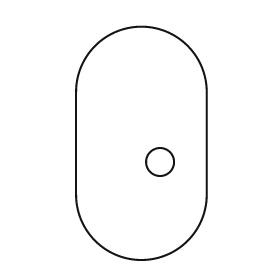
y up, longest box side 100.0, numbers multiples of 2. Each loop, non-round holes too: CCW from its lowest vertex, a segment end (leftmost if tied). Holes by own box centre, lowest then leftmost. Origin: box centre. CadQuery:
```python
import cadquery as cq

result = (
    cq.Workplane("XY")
    .moveTo(-28.0, -22.0)
    .threePointArc((0.0, -50.0), (28.0, -22.0))
    .lineTo(28.0, 22.0)
    .threePointArc((0.0, 50.0), (-28.0, 22.0))
    .close()
    .moveTo(8.0, -8.0)
    .circle(6.0)
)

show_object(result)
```